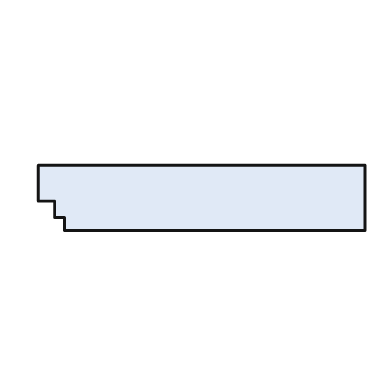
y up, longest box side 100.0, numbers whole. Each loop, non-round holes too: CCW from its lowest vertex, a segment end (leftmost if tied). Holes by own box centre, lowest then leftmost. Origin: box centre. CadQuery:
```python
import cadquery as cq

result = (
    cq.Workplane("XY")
    .moveTo(-42.0, -10.0)
    .lineTo(50.0, -10.0)
    .lineTo(50.0, 10.0)
    .lineTo(-50.0, 10.0)
    .lineTo(-50.0, -1.0)
    .lineTo(-45.0, -1.0)
    .lineTo(-45.0, -6.0)
    .lineTo(-42.0, -6.0)
    .close()
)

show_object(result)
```